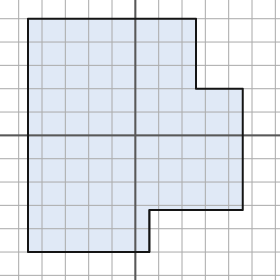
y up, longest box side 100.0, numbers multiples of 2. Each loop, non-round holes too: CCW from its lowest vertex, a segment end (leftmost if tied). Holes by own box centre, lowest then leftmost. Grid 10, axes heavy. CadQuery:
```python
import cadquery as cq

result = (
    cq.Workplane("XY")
    .moveTo(-46.0, -50.0)
    .lineTo(6.0, -50.0)
    .lineTo(6.0, -32.0)
    .lineTo(46.0, -32.0)
    .lineTo(46.0, 20.0)
    .lineTo(26.0, 20.0)
    .lineTo(26.0, 50.0)
    .lineTo(-46.0, 50.0)
    .close()
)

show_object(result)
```